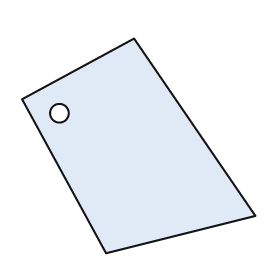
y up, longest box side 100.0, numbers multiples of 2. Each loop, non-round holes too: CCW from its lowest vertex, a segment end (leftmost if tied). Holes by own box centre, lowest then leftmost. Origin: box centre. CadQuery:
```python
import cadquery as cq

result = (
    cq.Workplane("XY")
    .moveTo(-14.0, -46.0)
    .lineTo(50.0, -30.0)
    .lineTo(-2.0, 46.0)
    .lineTo(-50.0, 20.0)
    .close()
    .moveTo(-34.0, 14.0)
    .circle(4.0)
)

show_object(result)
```